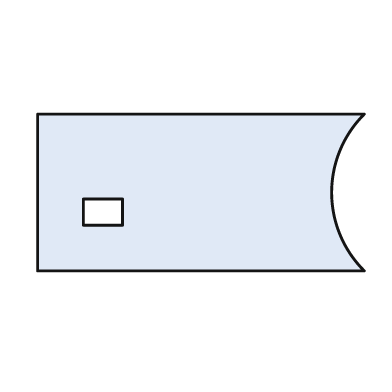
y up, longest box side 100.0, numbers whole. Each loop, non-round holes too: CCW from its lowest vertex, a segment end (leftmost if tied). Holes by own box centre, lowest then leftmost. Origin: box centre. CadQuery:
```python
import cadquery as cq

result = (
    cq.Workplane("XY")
    .moveTo(-50.0, -24.0)
    .lineTo(50.0, -24.0)
    .threePointArc((40.0, 0.0), (50.0, 24.0))
    .lineTo(-50.0, 24.0)
    .close()
    .moveTo(-36.0, -10.0)
    .lineTo(-24.0, -10.0)
    .lineTo(-24.0, -2.0)
    .lineTo(-36.0, -2.0)
    .close()
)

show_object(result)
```